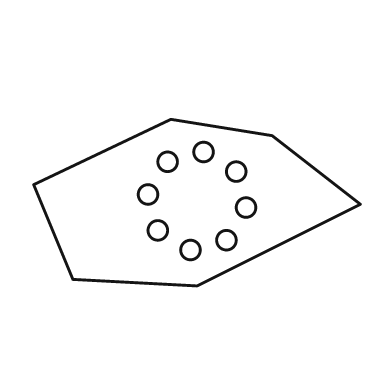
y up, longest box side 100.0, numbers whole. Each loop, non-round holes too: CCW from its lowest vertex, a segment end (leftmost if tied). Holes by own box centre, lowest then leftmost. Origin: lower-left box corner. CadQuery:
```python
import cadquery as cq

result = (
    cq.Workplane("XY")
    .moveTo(50.0, 0.0)
    .lineTo(100.0, 25.0)
    .lineTo(73.0, 46.0)
    .lineTo(42.0, 51.0)
    .lineTo(0.0, 31.0)
    .lineTo(12.0, 2.0)
    .close()
    .moveTo(48.0, 11.0)
    .circle(3.0)
    .moveTo(59.0, 14.0)
    .circle(3.0)
    .moveTo(38.0, 17.0)
    .circle(3.0)
    .moveTo(65.0, 24.0)
    .circle(3.0)
    .moveTo(35.0, 28.0)
    .circle(3.0)
    .moveTo(62.0, 35.0)
    .circle(3.0)
    .moveTo(41.0, 38.0)
    .circle(3.0)
    .moveTo(52.0, 41.0)
    .circle(3.0)
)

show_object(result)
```